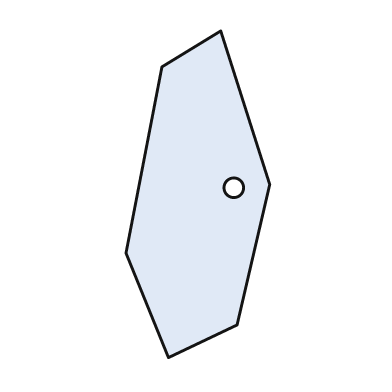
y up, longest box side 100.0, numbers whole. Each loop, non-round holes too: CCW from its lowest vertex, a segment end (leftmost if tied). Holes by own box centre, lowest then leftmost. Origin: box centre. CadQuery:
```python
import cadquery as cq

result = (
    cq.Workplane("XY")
    .moveTo(-9.0, -50.0)
    .lineTo(12.0, -40.0)
    .lineTo(22.0, 3.0)
    .lineTo(7.0, 50.0)
    .lineTo(-11.0, 39.0)
    .lineTo(-22.0, -18.0)
    .close()
    .moveTo(11.0, 2.0)
    .circle(3.0)
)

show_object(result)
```